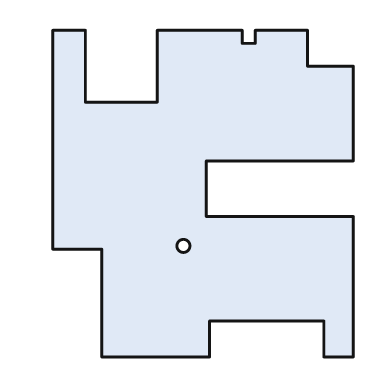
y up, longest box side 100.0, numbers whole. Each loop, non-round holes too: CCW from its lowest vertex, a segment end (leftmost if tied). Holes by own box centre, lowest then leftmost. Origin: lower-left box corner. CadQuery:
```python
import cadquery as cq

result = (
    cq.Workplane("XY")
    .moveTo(15.0, 0.0)
    .lineTo(48.0, 0.0)
    .lineTo(48.0, 11.0)
    .lineTo(83.0, 11.0)
    .lineTo(83.0, 0.0)
    .lineTo(92.0, 0.0)
    .lineTo(92.0, 43.0)
    .lineTo(47.0, 43.0)
    .lineTo(47.0, 60.0)
    .lineTo(92.0, 60.0)
    .lineTo(92.0, 89.0)
    .lineTo(78.0, 89.0)
    .lineTo(78.0, 100.0)
    .lineTo(62.0, 100.0)
    .lineTo(62.0, 96.0)
    .lineTo(58.0, 96.0)
    .lineTo(58.0, 100.0)
    .lineTo(32.0, 100.0)
    .lineTo(32.0, 78.0)
    .lineTo(10.0, 78.0)
    .lineTo(10.0, 100.0)
    .lineTo(0.0, 100.0)
    .lineTo(0.0, 33.0)
    .lineTo(15.0, 33.0)
    .close()
    .moveTo(40.0, 34.0)
    .circle(2.0)
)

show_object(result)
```